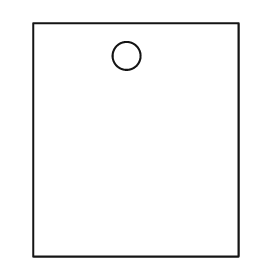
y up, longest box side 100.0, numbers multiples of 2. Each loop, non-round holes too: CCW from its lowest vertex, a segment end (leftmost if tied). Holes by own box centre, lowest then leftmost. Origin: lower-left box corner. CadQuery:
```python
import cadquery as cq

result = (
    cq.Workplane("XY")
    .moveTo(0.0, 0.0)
    .lineTo(88.0, 0.0)
    .lineTo(88.0, 100.0)
    .lineTo(0.0, 100.0)
    .close()
    .moveTo(40.0, 86.0)
    .circle(6.0)
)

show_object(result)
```